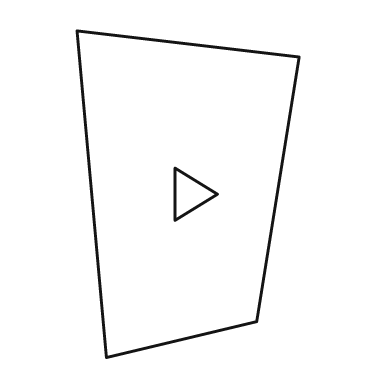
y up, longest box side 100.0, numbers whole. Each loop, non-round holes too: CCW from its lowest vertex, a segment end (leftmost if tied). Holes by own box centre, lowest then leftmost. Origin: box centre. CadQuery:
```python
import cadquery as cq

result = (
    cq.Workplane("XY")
    .moveTo(-25.0, -50.0)
    .lineTo(21.0, -39.0)
    .lineTo(34.0, 42.0)
    .lineTo(-34.0, 50.0)
    .close()
    .moveTo(-4.0, -8.0)
    .lineTo(9.0, 0.0)
    .lineTo(-4.0, 8.0)
    .close()
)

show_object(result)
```